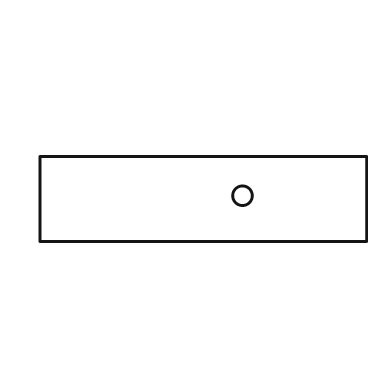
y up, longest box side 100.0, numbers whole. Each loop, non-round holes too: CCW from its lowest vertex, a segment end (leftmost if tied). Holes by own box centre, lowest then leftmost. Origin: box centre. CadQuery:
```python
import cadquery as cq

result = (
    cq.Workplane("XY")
    .moveTo(-50.0, -13.0)
    .lineTo(50.0, -13.0)
    .lineTo(50.0, 13.0)
    .lineTo(-50.0, 13.0)
    .close()
    .moveTo(12.0, 1.0)
    .circle(3.0)
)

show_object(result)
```